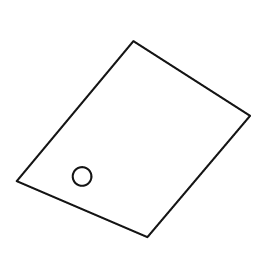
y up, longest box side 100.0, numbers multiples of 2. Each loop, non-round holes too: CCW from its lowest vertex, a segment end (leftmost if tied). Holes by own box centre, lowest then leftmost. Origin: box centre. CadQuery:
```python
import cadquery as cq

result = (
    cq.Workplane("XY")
    .moveTo(6.0, -42.0)
    .lineTo(50.0, 10.0)
    .lineTo(0.0, 42.0)
    .lineTo(-50.0, -18.0)
    .close()
    .moveTo(-22.0, -16.0)
    .circle(4.0)
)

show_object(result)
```